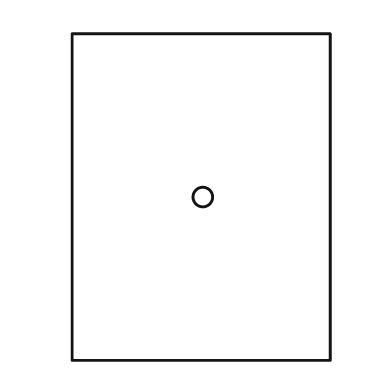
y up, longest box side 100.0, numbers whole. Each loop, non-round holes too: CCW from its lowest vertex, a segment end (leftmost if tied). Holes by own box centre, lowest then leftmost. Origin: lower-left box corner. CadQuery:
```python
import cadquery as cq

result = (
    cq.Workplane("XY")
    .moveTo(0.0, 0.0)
    .lineTo(79.0, 0.0)
    .lineTo(79.0, 100.0)
    .lineTo(0.0, 100.0)
    .close()
    .moveTo(40.0, 50.0)
    .circle(3.0)
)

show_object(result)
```